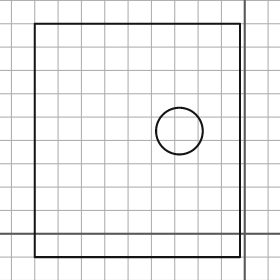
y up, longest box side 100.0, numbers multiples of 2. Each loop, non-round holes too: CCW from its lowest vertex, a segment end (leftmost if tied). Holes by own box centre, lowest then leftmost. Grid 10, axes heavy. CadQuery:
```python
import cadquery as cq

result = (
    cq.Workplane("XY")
    .moveTo(-90.0, -10.0)
    .lineTo(-2.0, -10.0)
    .lineTo(-2.0, 90.0)
    .lineTo(-90.0, 90.0)
    .close()
    .moveTo(-28.0, 44.0)
    .circle(10.0)
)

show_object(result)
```